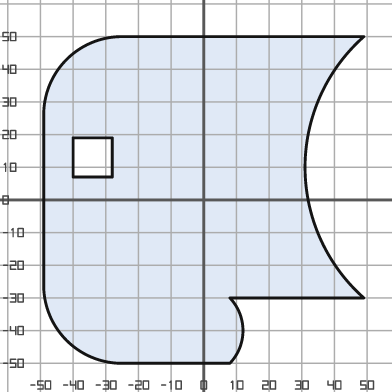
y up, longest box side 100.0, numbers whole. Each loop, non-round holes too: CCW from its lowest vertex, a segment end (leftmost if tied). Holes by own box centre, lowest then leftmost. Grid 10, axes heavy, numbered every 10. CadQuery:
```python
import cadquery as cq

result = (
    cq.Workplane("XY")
    .moveTo(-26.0, -50.0)
    .lineTo(8.0, -50.0)
    .threePointArc((12.0, -40.0), (8.0, -30.0))
    .lineTo(49.0, -30.0)
    .threePointArc((31.0, 10.0), (49.0, 50.0))
    .lineTo(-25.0, 50.0)
    .threePointArc((-42.0, 43.0), (-49.0, 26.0))
    .lineTo(-49.0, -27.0)
    .threePointArc((-42.0, -43.0), (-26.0, -50.0))
    .close()
    .moveTo(-40.0, 7.0)
    .lineTo(-28.0, 7.0)
    .lineTo(-28.0, 19.0)
    .lineTo(-40.0, 19.0)
    .close()
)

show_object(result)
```